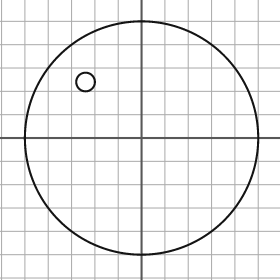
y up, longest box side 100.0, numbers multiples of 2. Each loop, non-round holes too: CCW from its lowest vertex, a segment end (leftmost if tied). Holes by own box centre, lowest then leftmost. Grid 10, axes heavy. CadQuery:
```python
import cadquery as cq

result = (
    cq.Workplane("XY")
    .moveTo(0.0, 0.0)
    .circle(50.0)
    .moveTo(-24.0, 24.0)
    .circle(4.0)
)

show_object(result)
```